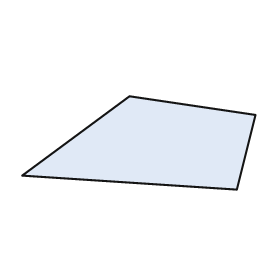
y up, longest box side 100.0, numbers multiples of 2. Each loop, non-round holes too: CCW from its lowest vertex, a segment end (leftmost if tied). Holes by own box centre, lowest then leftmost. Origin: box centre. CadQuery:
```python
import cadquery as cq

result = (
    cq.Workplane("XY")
    .moveTo(42.0, -20.0)
    .lineTo(50.0, 12.0)
    .lineTo(-4.0, 20.0)
    .lineTo(-50.0, -14.0)
    .close()
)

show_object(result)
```